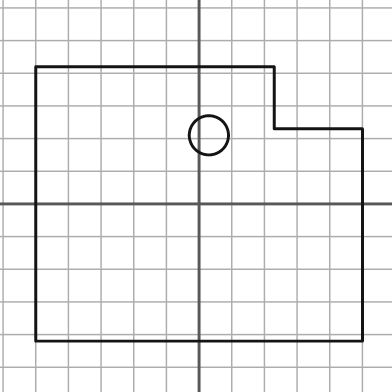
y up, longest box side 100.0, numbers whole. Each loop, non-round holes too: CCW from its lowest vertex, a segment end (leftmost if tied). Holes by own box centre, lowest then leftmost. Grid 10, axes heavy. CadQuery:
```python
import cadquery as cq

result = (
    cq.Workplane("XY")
    .moveTo(-50.0, -42.0)
    .lineTo(50.0, -42.0)
    .lineTo(50.0, 23.0)
    .lineTo(23.0, 23.0)
    .lineTo(23.0, 42.0)
    .lineTo(-50.0, 42.0)
    .close()
    .moveTo(3.0, 21.0)
    .circle(6.0)
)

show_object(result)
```